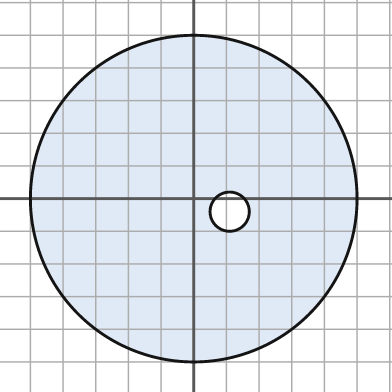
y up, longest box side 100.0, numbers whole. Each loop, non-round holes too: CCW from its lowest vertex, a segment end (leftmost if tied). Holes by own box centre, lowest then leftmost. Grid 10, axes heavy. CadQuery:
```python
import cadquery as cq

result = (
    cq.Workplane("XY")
    .moveTo(0.0, 0.0)
    .circle(50.0)
    .moveTo(11.0, -4.0)
    .circle(6.0)
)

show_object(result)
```